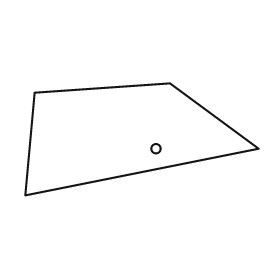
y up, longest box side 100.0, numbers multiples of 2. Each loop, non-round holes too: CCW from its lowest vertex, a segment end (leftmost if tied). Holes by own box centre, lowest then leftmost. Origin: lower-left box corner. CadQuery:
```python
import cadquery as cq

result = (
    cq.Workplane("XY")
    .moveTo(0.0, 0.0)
    .lineTo(100.0, 20.0)
    .lineTo(62.0, 48.0)
    .lineTo(4.0, 44.0)
    .close()
    .moveTo(56.0, 20.0)
    .circle(2.0)
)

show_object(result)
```